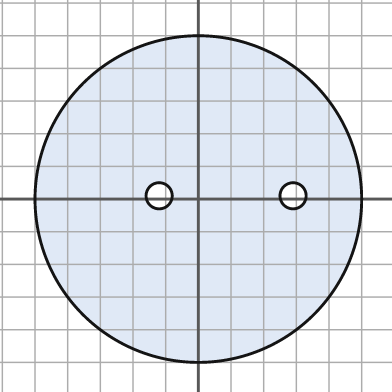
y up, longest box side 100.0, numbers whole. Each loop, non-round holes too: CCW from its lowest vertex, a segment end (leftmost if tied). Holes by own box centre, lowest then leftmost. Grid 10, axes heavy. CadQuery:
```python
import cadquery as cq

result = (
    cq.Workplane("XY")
    .moveTo(0.0, 0.0)
    .circle(50.0)
    .moveTo(-12.0, 1.0)
    .circle(4.0)
    .moveTo(29.0, 1.0)
    .circle(4.0)
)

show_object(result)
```